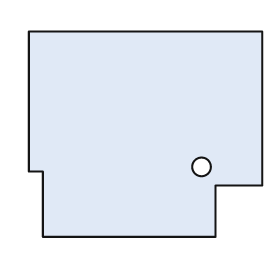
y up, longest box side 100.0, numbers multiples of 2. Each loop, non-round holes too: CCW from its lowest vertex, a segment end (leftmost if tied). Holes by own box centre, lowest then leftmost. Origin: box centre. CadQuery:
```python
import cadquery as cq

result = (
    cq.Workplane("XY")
    .moveTo(-44.0, -44.0)
    .lineTo(30.0, -44.0)
    .lineTo(30.0, -22.0)
    .lineTo(50.0, -22.0)
    .lineTo(50.0, 44.0)
    .lineTo(-50.0, 44.0)
    .lineTo(-50.0, -16.0)
    .lineTo(-44.0, -16.0)
    .close()
    .moveTo(24.0, -14.0)
    .circle(4.0)
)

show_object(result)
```